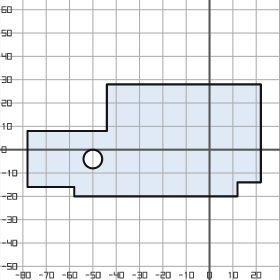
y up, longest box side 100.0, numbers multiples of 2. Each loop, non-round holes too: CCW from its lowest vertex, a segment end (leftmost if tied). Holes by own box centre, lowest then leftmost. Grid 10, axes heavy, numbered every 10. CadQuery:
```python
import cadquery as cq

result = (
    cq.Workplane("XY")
    .moveTo(-58.0, -20.0)
    .lineTo(12.0, -20.0)
    .lineTo(12.0, -14.0)
    .lineTo(22.0, -14.0)
    .lineTo(22.0, 28.0)
    .lineTo(-44.0, 28.0)
    .lineTo(-44.0, 8.0)
    .lineTo(-78.0, 8.0)
    .lineTo(-78.0, -16.0)
    .lineTo(-58.0, -16.0)
    .close()
    .moveTo(-50.0, -4.0)
    .circle(4.0)
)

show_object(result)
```